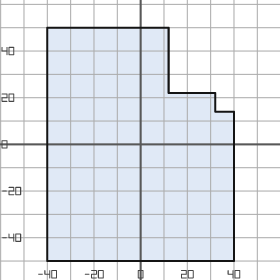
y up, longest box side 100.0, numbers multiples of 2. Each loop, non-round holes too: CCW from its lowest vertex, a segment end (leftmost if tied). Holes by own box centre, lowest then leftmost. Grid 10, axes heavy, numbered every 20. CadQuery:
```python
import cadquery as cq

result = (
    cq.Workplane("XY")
    .moveTo(-40.0, -50.0)
    .lineTo(40.0, -50.0)
    .lineTo(40.0, 14.0)
    .lineTo(32.0, 14.0)
    .lineTo(32.0, 22.0)
    .lineTo(12.0, 22.0)
    .lineTo(12.0, 50.0)
    .lineTo(-40.0, 50.0)
    .close()
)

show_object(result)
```